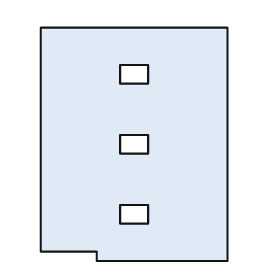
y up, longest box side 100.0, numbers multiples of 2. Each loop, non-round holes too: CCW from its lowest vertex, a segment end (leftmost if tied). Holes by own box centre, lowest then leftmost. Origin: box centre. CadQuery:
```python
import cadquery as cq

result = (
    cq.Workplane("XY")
    .moveTo(-16.0, -50.0)
    .lineTo(40.0, -50.0)
    .lineTo(40.0, 50.0)
    .lineTo(-40.0, 50.0)
    .lineTo(-40.0, -46.0)
    .lineTo(-16.0, -46.0)
    .close()
    .moveTo(-6.0, -34.0)
    .lineTo(6.0, -34.0)
    .lineTo(6.0, -26.0)
    .lineTo(-6.0, -26.0)
    .close()
    .moveTo(-6.0, -4.0)
    .lineTo(6.0, -4.0)
    .lineTo(6.0, 4.0)
    .lineTo(-6.0, 4.0)
    .close()
    .moveTo(-6.0, 26.0)
    .lineTo(6.0, 26.0)
    .lineTo(6.0, 34.0)
    .lineTo(-6.0, 34.0)
    .close()
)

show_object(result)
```